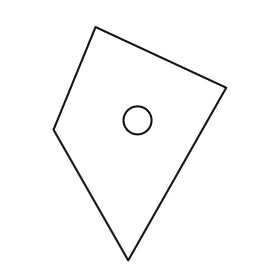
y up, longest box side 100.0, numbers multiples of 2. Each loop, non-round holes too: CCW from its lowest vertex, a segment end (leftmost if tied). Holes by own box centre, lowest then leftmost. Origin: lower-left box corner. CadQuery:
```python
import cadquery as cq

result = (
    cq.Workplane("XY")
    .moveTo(32.0, 0.0)
    .lineTo(74.0, 74.0)
    .lineTo(18.0, 100.0)
    .lineTo(0.0, 56.0)
    .close()
    .moveTo(36.0, 60.0)
    .circle(6.0)
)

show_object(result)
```